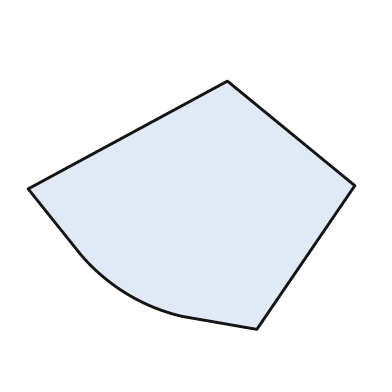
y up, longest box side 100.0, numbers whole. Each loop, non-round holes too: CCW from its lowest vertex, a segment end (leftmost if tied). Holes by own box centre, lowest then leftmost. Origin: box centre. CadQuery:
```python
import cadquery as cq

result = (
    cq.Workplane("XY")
    .moveTo(20.0, -38.0)
    .lineTo(50.0, 6.0)
    .lineTo(11.0, 38.0)
    .lineTo(-50.0, 5.0)
    .lineTo(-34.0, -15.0)
    .threePointArc((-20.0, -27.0), (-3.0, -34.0))
    .close()
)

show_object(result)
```